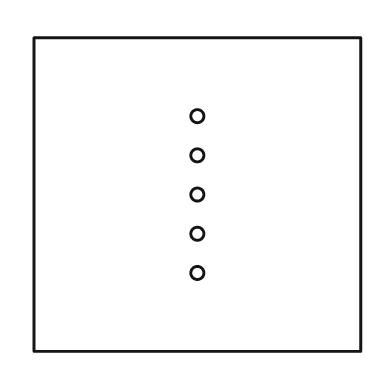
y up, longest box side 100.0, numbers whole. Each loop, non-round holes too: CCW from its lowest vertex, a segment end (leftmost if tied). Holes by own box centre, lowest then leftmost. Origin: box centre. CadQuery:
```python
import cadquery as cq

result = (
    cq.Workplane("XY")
    .moveTo(-50.0, -48.0)
    .lineTo(50.0, -48.0)
    .lineTo(50.0, 48.0)
    .lineTo(-50.0, 48.0)
    .close()
    .moveTo(0.0, -24.0)
    .circle(2.0)
    .moveTo(0.0, -12.0)
    .circle(2.0)
    .moveTo(0.0, 0.0)
    .circle(2.0)
    .moveTo(0.0, 12.0)
    .circle(2.0)
    .moveTo(0.0, 24.0)
    .circle(2.0)
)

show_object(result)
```